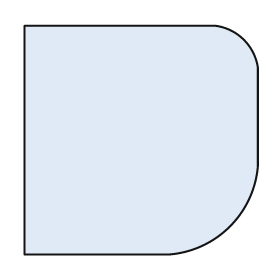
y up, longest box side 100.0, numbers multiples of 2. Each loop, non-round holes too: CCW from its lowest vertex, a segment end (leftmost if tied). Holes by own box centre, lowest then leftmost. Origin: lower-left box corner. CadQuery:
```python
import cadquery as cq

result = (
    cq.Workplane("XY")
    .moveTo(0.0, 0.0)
    .lineTo(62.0, 0.0)
    .threePointArc((88.0, 12.0), (100.0, 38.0))
    .lineTo(100.0, 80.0)
    .threePointArc((94.0, 92.0), (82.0, 98.0))
    .lineTo(0.0, 98.0)
    .close()
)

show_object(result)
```